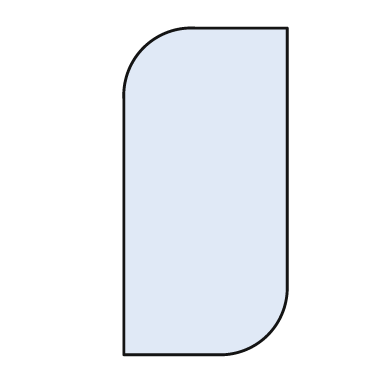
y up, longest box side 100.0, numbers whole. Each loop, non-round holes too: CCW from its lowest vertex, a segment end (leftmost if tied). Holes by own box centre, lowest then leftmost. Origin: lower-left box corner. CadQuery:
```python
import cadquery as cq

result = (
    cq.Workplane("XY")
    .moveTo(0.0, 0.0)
    .lineTo(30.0, 0.0)
    .threePointArc((44.0, 6.0), (50.0, 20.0))
    .lineTo(50.0, 100.0)
    .lineTo(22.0, 100.0)
    .threePointArc((6.0, 94.0), (0.0, 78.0))
    .close()
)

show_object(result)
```